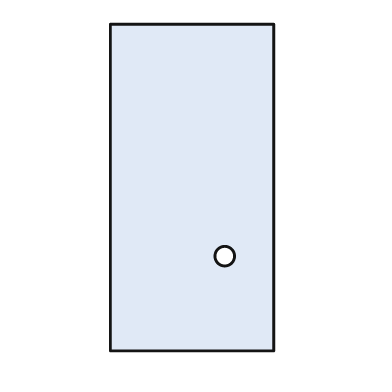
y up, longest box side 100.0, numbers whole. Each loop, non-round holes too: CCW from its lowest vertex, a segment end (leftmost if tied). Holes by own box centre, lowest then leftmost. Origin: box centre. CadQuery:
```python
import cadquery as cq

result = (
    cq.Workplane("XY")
    .moveTo(-25.0, -50.0)
    .lineTo(25.0, -50.0)
    .lineTo(25.0, 50.0)
    .lineTo(-25.0, 50.0)
    .close()
    .moveTo(10.0, -21.0)
    .circle(3.0)
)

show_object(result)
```